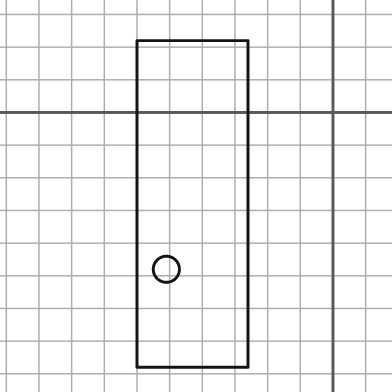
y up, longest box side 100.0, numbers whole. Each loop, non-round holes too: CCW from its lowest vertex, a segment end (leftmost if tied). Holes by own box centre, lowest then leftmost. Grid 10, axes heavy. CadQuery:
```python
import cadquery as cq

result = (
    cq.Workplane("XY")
    .moveTo(-60.0, -78.0)
    .lineTo(-26.0, -78.0)
    .lineTo(-26.0, 22.0)
    .lineTo(-60.0, 22.0)
    .close()
    .moveTo(-51.0, -48.0)
    .circle(4.0)
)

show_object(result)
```